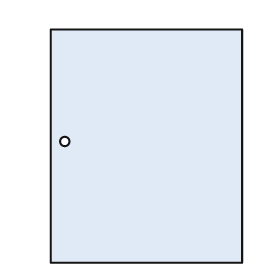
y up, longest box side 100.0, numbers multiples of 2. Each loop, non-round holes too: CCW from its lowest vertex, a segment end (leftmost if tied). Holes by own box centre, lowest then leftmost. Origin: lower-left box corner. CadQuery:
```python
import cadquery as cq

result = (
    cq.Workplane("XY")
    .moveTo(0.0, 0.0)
    .lineTo(82.0, 0.0)
    .lineTo(82.0, 100.0)
    .lineTo(0.0, 100.0)
    .close()
    .moveTo(6.0, 52.0)
    .circle(2.0)
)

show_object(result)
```